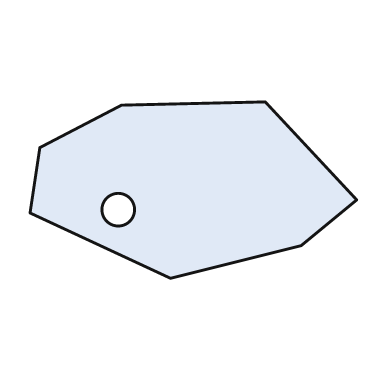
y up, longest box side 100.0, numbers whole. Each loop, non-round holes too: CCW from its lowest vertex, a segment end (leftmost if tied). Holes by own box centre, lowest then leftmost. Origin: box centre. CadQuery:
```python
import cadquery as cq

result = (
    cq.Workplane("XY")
    .moveTo(-7.0, -27.0)
    .lineTo(33.0, -17.0)
    .lineTo(50.0, -3.0)
    .lineTo(22.0, 27.0)
    .lineTo(-22.0, 26.0)
    .lineTo(-47.0, 13.0)
    .lineTo(-50.0, -7.0)
    .close()
    .moveTo(-23.0, -6.0)
    .circle(5.0)
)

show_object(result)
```